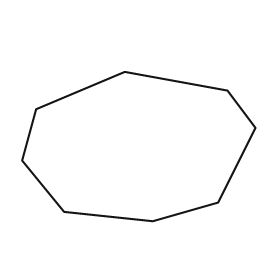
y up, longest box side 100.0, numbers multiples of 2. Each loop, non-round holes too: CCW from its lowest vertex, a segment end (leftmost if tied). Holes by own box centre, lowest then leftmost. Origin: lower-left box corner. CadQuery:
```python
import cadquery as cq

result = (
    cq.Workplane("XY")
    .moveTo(56.0, 0.0)
    .lineTo(84.0, 8.0)
    .lineTo(100.0, 40.0)
    .lineTo(88.0, 56.0)
    .lineTo(44.0, 64.0)
    .lineTo(6.0, 48.0)
    .lineTo(0.0, 26.0)
    .lineTo(18.0, 4.0)
    .close()
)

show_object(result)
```